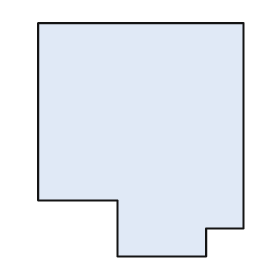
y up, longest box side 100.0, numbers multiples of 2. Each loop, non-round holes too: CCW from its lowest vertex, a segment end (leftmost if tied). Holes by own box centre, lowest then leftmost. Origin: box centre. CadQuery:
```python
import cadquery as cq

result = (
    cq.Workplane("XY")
    .moveTo(-10.0, -50.0)
    .lineTo(28.0, -50.0)
    .lineTo(28.0, -38.0)
    .lineTo(44.0, -38.0)
    .lineTo(44.0, 50.0)
    .lineTo(-44.0, 50.0)
    .lineTo(-44.0, -26.0)
    .lineTo(-10.0, -26.0)
    .close()
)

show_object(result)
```